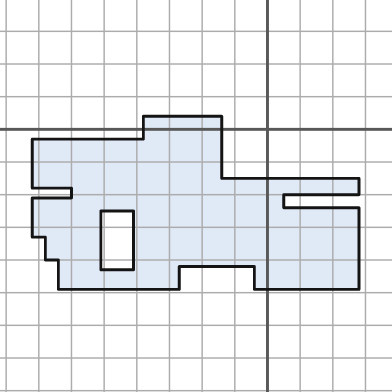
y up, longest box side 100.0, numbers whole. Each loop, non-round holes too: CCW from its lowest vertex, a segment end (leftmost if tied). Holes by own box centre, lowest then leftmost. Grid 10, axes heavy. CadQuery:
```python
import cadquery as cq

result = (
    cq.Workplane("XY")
    .moveTo(-64.0, -49.0)
    .lineTo(-27.0, -49.0)
    .lineTo(-27.0, -42.0)
    .lineTo(-4.0, -42.0)
    .lineTo(-4.0, -49.0)
    .lineTo(28.0, -49.0)
    .lineTo(28.0, -24.0)
    .lineTo(5.0, -24.0)
    .lineTo(5.0, -20.0)
    .lineTo(28.0, -20.0)
    .lineTo(28.0, -15.0)
    .lineTo(-14.0, -15.0)
    .lineTo(-14.0, 4.0)
    .lineTo(-38.0, 4.0)
    .lineTo(-38.0, -3.0)
    .lineTo(-72.0, -3.0)
    .lineTo(-72.0, -18.0)
    .lineTo(-60.0, -18.0)
    .lineTo(-60.0, -21.0)
    .lineTo(-72.0, -21.0)
    .lineTo(-72.0, -33.0)
    .lineTo(-68.0, -33.0)
    .lineTo(-68.0, -40.0)
    .lineTo(-64.0, -40.0)
    .close()
    .moveTo(-51.0, -43.0)
    .lineTo(-41.0, -43.0)
    .lineTo(-41.0, -25.0)
    .lineTo(-51.0, -25.0)
    .close()
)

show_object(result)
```